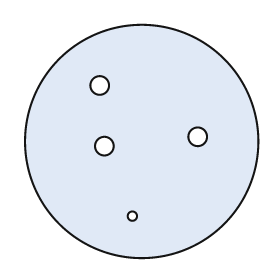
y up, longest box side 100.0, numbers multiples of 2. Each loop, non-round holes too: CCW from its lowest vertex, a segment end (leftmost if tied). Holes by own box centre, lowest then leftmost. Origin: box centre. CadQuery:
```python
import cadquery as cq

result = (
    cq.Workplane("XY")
    .moveTo(0.0, 0.0)
    .circle(50.0)
    .moveTo(-4.0, -32.0)
    .circle(2.0)
    .moveTo(-16.0, -2.0)
    .circle(4.0)
    .moveTo(24.0, 2.0)
    .circle(4.0)
    .moveTo(-18.0, 24.0)
    .circle(4.0)
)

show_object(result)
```